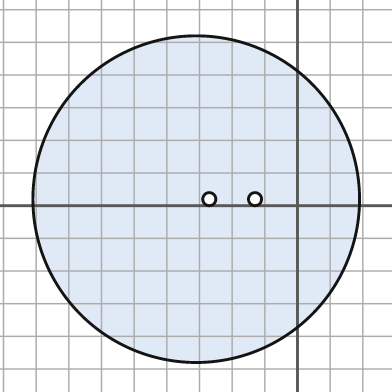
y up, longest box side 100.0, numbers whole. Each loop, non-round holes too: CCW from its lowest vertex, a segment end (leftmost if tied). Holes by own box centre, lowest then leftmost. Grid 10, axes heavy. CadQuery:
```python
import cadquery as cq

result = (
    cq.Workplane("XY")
    .moveTo(-31.0, 2.0)
    .circle(50.0)
    .moveTo(-27.0, 2.0)
    .circle(2.0)
    .moveTo(-13.0, 2.0)
    .circle(2.0)
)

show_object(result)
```